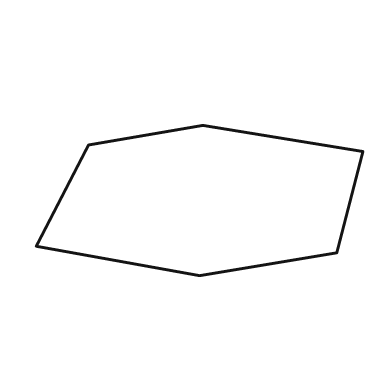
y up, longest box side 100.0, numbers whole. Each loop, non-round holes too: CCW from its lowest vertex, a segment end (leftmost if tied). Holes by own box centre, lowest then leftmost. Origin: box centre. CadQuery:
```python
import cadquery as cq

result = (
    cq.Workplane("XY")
    .moveTo(0.0, -23.0)
    .lineTo(42.0, -16.0)
    .lineTo(50.0, 15.0)
    .lineTo(1.0, 23.0)
    .lineTo(-34.0, 17.0)
    .lineTo(-50.0, -14.0)
    .close()
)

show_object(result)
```